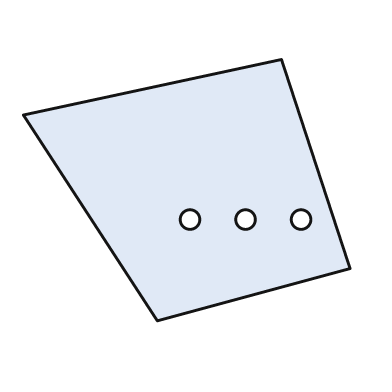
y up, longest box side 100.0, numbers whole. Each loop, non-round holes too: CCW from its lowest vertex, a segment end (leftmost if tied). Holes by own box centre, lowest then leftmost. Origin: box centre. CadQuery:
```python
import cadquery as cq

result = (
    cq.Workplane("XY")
    .moveTo(-9.0, -40.0)
    .lineTo(50.0, -24.0)
    .lineTo(29.0, 40.0)
    .lineTo(-50.0, 23.0)
    .close()
    .moveTo(1.0, -9.0)
    .circle(3.0)
    .moveTo(18.0, -9.0)
    .circle(3.0)
    .moveTo(35.0, -9.0)
    .circle(3.0)
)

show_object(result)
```